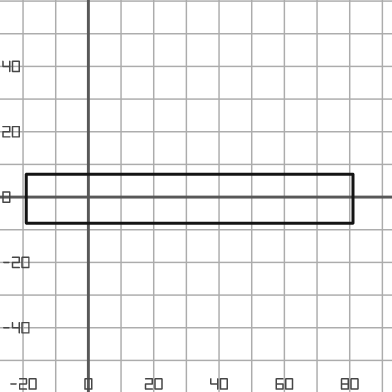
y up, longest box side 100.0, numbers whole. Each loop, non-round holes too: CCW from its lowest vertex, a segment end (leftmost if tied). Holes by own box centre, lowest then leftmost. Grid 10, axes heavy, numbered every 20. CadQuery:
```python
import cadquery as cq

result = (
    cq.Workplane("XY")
    .moveTo(-19.0, -8.0)
    .lineTo(81.0, -8.0)
    .lineTo(81.0, 7.0)
    .lineTo(-19.0, 7.0)
    .close()
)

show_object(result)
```